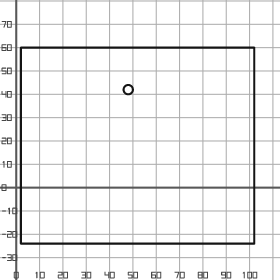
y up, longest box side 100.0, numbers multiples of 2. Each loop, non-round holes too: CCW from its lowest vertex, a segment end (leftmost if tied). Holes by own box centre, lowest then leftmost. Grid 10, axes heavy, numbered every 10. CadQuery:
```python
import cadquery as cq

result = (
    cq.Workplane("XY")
    .moveTo(2.0, -24.0)
    .lineTo(102.0, -24.0)
    .lineTo(102.0, 60.0)
    .lineTo(2.0, 60.0)
    .close()
    .moveTo(48.0, 42.0)
    .circle(2.0)
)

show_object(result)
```